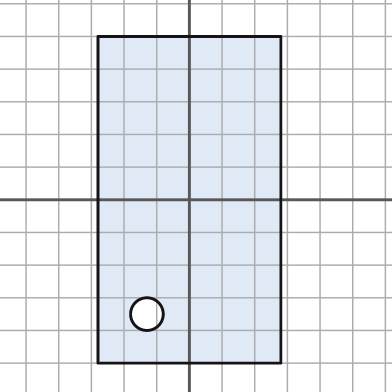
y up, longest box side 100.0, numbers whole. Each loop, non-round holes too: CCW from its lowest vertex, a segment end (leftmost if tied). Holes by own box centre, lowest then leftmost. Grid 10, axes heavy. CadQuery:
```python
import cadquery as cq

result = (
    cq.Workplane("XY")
    .moveTo(-28.0, -50.0)
    .lineTo(28.0, -50.0)
    .lineTo(28.0, 50.0)
    .lineTo(-28.0, 50.0)
    .close()
    .moveTo(-13.0, -35.0)
    .circle(5.0)
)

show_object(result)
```